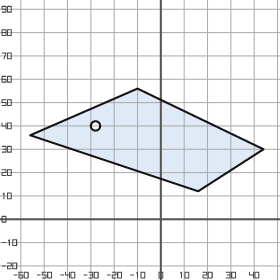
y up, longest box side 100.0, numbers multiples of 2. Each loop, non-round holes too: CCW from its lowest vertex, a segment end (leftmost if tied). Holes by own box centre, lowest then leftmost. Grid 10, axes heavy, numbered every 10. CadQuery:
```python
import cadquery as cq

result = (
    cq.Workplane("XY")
    .moveTo(16.0, 12.0)
    .lineTo(44.0, 30.0)
    .lineTo(-10.0, 56.0)
    .lineTo(-56.0, 36.0)
    .close()
    .moveTo(-28.0, 40.0)
    .circle(2.0)
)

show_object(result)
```